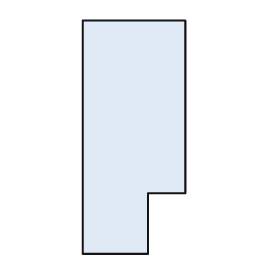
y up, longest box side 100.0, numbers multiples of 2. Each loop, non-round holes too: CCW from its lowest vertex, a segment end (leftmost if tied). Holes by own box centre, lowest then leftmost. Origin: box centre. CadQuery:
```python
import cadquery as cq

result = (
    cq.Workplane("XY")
    .moveTo(-22.0, -50.0)
    .lineTo(6.0, -50.0)
    .lineTo(6.0, -24.0)
    .lineTo(22.0, -24.0)
    .lineTo(22.0, 50.0)
    .lineTo(-22.0, 50.0)
    .close()
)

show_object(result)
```